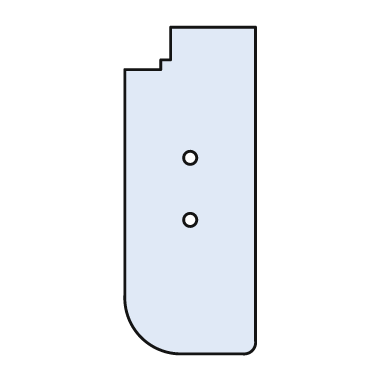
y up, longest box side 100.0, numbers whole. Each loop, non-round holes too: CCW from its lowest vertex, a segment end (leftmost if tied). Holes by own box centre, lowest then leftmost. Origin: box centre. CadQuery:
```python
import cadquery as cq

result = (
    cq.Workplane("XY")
    .moveTo(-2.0, -50.0)
    .lineTo(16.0, -50.0)
    .threePointArc((19.0, -49.0), (20.0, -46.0))
    .lineTo(20.0, 50.0)
    .lineTo(-6.0, 50.0)
    .lineTo(-6.0, 40.0)
    .lineTo(-9.0, 40.0)
    .lineTo(-9.0, 37.0)
    .lineTo(-20.0, 37.0)
    .lineTo(-20.0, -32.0)
    .threePointArc((-15.0, -45.0), (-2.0, -50.0))
    .close()
    .moveTo(0.0, -9.0)
    .circle(2.0)
    .moveTo(0.0, 10.0)
    .circle(2.0)
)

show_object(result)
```